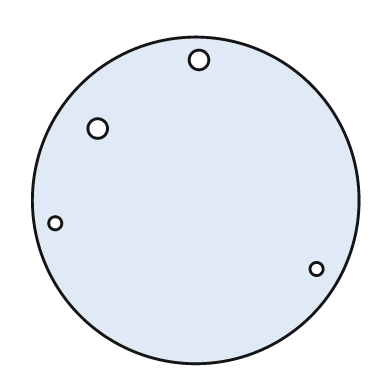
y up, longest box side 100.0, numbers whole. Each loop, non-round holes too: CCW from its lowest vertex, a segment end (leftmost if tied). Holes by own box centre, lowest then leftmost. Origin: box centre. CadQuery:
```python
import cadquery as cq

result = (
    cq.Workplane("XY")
    .moveTo(0.0, 0.0)
    .circle(50.0)
    .moveTo(37.0, -21.0)
    .circle(2.0)
    .moveTo(-43.0, -7.0)
    .circle(2.0)
    .moveTo(-30.0, 22.0)
    .circle(3.0)
    .moveTo(1.0, 43.0)
    .circle(3.0)
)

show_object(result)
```